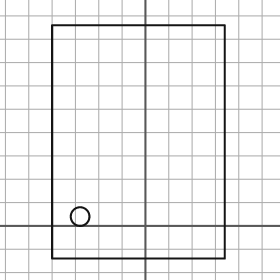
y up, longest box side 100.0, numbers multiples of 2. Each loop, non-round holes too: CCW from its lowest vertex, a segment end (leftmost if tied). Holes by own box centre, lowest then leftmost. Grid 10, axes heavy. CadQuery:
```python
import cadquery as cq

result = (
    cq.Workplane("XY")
    .moveTo(-40.0, -14.0)
    .lineTo(34.0, -14.0)
    .lineTo(34.0, 86.0)
    .lineTo(-40.0, 86.0)
    .close()
    .moveTo(-28.0, 4.0)
    .circle(4.0)
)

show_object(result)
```